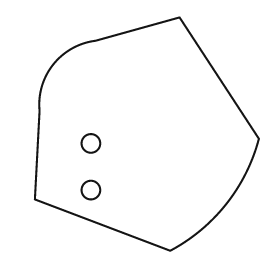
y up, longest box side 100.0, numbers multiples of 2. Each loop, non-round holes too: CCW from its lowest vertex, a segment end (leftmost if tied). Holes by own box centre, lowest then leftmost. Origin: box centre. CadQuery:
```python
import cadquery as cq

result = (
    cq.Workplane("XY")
    .moveTo(10.0, -50.0)
    .threePointArc((34.0, -30.0), (48.0, -2.0))
    .lineTo(14.0, 50.0)
    .lineTo(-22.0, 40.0)
    .threePointArc((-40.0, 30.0), (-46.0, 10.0))
    .lineTo(-48.0, -28.0)
    .close()
    .moveTo(-24.0, -24.0)
    .circle(4.0)
    .moveTo(-24.0, -4.0)
    .circle(4.0)
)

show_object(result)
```